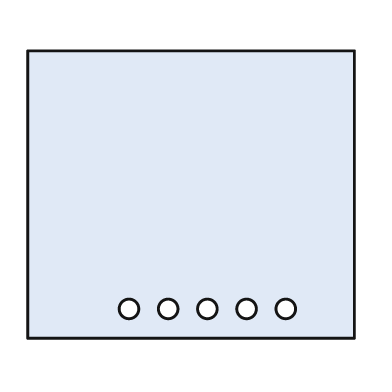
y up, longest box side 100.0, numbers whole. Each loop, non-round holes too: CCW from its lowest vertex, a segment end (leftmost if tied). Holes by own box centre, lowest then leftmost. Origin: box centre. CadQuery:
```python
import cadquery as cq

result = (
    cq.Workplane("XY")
    .moveTo(-50.0, -44.0)
    .lineTo(50.0, -44.0)
    .lineTo(50.0, 44.0)
    .lineTo(-50.0, 44.0)
    .close()
    .moveTo(-19.0, -35.0)
    .circle(3.0)
    .moveTo(-7.0, -35.0)
    .circle(3.0)
    .moveTo(5.0, -35.0)
    .circle(3.0)
    .moveTo(17.0, -35.0)
    .circle(3.0)
    .moveTo(29.0, -35.0)
    .circle(3.0)
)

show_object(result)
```